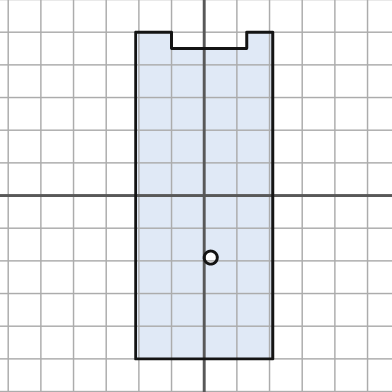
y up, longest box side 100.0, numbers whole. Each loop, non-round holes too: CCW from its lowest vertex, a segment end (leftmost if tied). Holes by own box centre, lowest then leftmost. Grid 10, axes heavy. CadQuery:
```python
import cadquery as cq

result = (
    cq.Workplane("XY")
    .moveTo(-21.0, -50.0)
    .lineTo(21.0, -50.0)
    .lineTo(21.0, 50.0)
    .lineTo(13.0, 50.0)
    .lineTo(13.0, 45.0)
    .lineTo(-10.0, 45.0)
    .lineTo(-10.0, 50.0)
    .lineTo(-21.0, 50.0)
    .close()
    .moveTo(2.0, -19.0)
    .circle(2.0)
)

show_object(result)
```